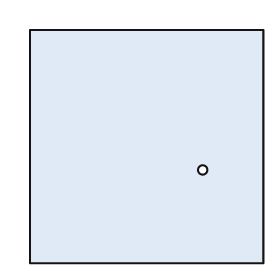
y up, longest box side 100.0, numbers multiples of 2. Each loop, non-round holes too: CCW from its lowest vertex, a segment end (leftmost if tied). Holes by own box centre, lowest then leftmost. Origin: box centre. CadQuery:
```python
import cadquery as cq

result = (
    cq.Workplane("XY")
    .moveTo(-50.0, -50.0)
    .lineTo(50.0, -50.0)
    .lineTo(50.0, 50.0)
    .lineTo(-50.0, 50.0)
    .close()
    .moveTo(24.0, -10.0)
    .circle(2.0)
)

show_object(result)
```